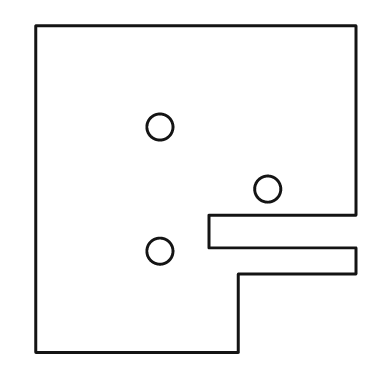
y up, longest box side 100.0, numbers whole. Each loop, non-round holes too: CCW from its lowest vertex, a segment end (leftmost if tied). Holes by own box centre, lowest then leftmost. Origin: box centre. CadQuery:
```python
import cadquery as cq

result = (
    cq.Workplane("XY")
    .moveTo(-49.0, -50.0)
    .lineTo(13.0, -50.0)
    .lineTo(13.0, -26.0)
    .lineTo(49.0, -26.0)
    .lineTo(49.0, -18.0)
    .lineTo(4.0, -18.0)
    .lineTo(4.0, -8.0)
    .lineTo(49.0, -8.0)
    .lineTo(49.0, 50.0)
    .lineTo(-49.0, 50.0)
    .close()
    .moveTo(-11.0, -19.0)
    .circle(4.0)
    .moveTo(22.0, 0.0)
    .circle(4.0)
    .moveTo(-11.0, 19.0)
    .circle(4.0)
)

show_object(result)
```